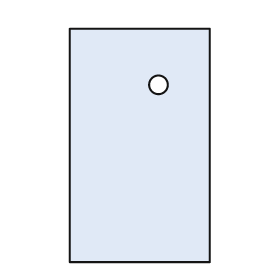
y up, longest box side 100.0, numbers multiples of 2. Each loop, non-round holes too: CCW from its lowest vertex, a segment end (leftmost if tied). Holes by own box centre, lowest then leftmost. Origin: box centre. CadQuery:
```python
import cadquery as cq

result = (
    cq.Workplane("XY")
    .moveTo(-30.0, -50.0)
    .lineTo(30.0, -50.0)
    .lineTo(30.0, 50.0)
    .lineTo(-30.0, 50.0)
    .close()
    .moveTo(8.0, 26.0)
    .circle(4.0)
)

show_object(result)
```